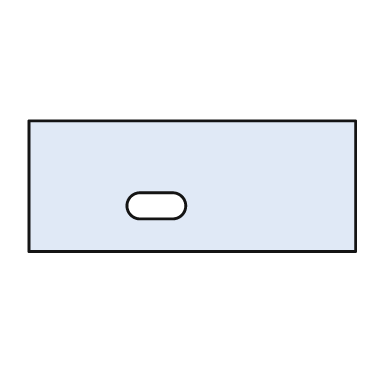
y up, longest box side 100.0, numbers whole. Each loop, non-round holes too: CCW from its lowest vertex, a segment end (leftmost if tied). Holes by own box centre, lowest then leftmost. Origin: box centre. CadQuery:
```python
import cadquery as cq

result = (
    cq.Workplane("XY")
    .moveTo(-50.0, -20.0)
    .lineTo(50.0, -20.0)
    .lineTo(50.0, 20.0)
    .lineTo(-50.0, 20.0)
    .close()
    .moveTo(-16.0, -10.0)
    .lineTo(-6.0, -10.0)
    .threePointArc((-2.0, -6.0), (-6.0, -2.0))
    .lineTo(-16.0, -2.0)
    .threePointArc((-20.0, -6.0), (-16.0, -10.0))
    .close()
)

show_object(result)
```